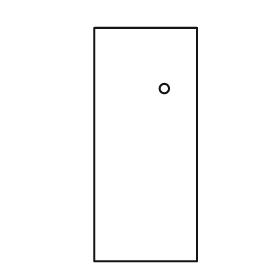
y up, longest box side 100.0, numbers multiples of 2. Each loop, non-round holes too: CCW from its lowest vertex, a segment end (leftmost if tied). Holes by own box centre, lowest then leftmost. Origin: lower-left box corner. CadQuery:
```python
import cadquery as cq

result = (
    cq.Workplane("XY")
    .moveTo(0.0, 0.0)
    .lineTo(44.0, 0.0)
    .lineTo(44.0, 100.0)
    .lineTo(0.0, 100.0)
    .close()
    .moveTo(30.0, 74.0)
    .circle(2.0)
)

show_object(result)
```